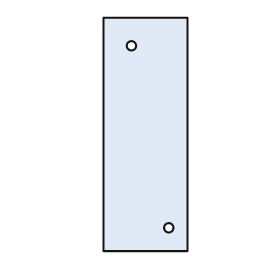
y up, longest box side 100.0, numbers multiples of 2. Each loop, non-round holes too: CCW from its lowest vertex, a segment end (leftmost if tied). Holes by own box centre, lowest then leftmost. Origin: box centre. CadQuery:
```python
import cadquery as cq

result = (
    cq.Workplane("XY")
    .moveTo(-18.0, -50.0)
    .lineTo(18.0, -50.0)
    .lineTo(18.0, 50.0)
    .lineTo(-18.0, 50.0)
    .close()
    .moveTo(10.0, -40.0)
    .circle(2.0)
    .moveTo(-6.0, 38.0)
    .circle(2.0)
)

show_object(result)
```